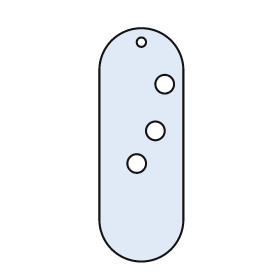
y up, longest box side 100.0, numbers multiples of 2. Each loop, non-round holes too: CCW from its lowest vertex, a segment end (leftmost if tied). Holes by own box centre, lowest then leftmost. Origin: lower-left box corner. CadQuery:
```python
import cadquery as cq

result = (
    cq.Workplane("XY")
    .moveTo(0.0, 18.0)
    .threePointArc((18.0, 0.0), (36.0, 18.0))
    .lineTo(36.0, 82.0)
    .threePointArc((18.0, 100.0), (0.0, 82.0))
    .close()
    .moveTo(16.0, 42.0)
    .circle(4.0)
    .moveTo(24.0, 56.0)
    .circle(4.0)
    .moveTo(28.0, 76.0)
    .circle(4.0)
    .moveTo(18.0, 94.0)
    .circle(2.0)
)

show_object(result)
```